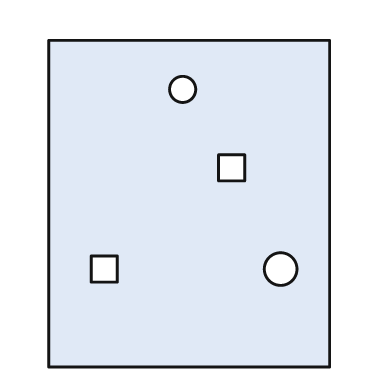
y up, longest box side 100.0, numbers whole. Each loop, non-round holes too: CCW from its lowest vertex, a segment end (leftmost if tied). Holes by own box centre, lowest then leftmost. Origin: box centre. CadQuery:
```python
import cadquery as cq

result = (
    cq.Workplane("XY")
    .moveTo(-43.0, -50.0)
    .lineTo(43.0, -50.0)
    .lineTo(43.0, 50.0)
    .lineTo(-43.0, 50.0)
    .close()
    .moveTo(-30.0, -24.0)
    .lineTo(-22.0, -24.0)
    .lineTo(-22.0, -16.0)
    .lineTo(-30.0, -16.0)
    .close()
    .moveTo(28.0, -20.0)
    .circle(5.0)
    .moveTo(9.0, 7.0)
    .lineTo(17.0, 7.0)
    .lineTo(17.0, 15.0)
    .lineTo(9.0, 15.0)
    .close()
    .moveTo(-2.0, 35.0)
    .circle(4.0)
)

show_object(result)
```